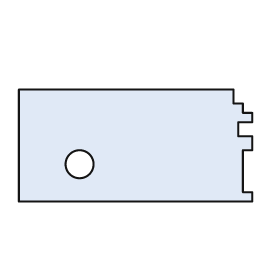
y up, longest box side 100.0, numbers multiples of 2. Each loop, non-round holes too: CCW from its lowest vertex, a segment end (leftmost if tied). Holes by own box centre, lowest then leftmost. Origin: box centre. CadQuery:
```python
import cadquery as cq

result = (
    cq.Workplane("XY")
    .moveTo(-50.0, -24.0)
    .lineTo(50.0, -24.0)
    .lineTo(50.0, -20.0)
    .lineTo(46.0, -20.0)
    .lineTo(46.0, -2.0)
    .lineTo(50.0, -2.0)
    .lineTo(50.0, 4.0)
    .lineTo(44.0, 4.0)
    .lineTo(44.0, 10.0)
    .lineTo(50.0, 10.0)
    .lineTo(50.0, 14.0)
    .lineTo(46.0, 14.0)
    .lineTo(46.0, 18.0)
    .lineTo(42.0, 18.0)
    .lineTo(42.0, 24.0)
    .lineTo(-50.0, 24.0)
    .close()
    .moveTo(-24.0, -8.0)
    .circle(6.0)
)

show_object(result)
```